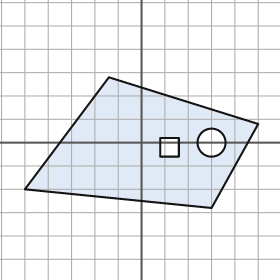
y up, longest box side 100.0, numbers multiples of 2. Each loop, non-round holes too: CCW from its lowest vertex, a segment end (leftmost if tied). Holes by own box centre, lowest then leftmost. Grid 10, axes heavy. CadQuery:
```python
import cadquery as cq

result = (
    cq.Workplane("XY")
    .moveTo(30.0, -28.0)
    .lineTo(50.0, 8.0)
    .lineTo(-14.0, 28.0)
    .lineTo(-50.0, -20.0)
    .close()
    .moveTo(8.0, -6.0)
    .lineTo(16.0, -6.0)
    .lineTo(16.0, 2.0)
    .lineTo(8.0, 2.0)
    .close()
    .moveTo(30.0, 0.0)
    .circle(6.0)
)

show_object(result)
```